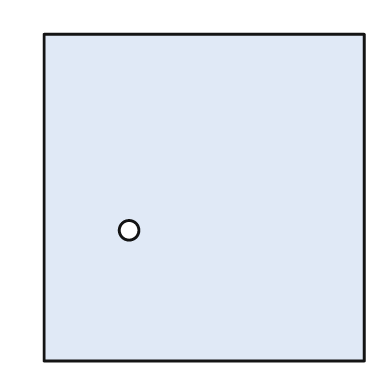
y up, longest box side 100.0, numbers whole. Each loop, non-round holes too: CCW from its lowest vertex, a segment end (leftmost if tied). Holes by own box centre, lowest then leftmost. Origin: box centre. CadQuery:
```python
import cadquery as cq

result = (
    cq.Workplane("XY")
    .moveTo(-49.0, -50.0)
    .lineTo(49.0, -50.0)
    .lineTo(49.0, 50.0)
    .lineTo(-49.0, 50.0)
    .close()
    .moveTo(-23.0, -10.0)
    .circle(3.0)
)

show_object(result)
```